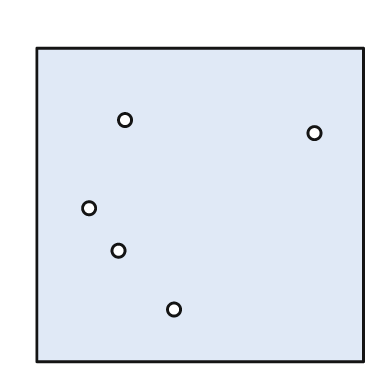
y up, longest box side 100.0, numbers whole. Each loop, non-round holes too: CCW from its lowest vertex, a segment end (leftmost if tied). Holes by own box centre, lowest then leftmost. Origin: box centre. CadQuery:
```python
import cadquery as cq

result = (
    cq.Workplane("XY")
    .moveTo(-50.0, -48.0)
    .lineTo(50.0, -48.0)
    .lineTo(50.0, 48.0)
    .lineTo(-50.0, 48.0)
    .close()
    .moveTo(-8.0, -32.0)
    .circle(2.0)
    .moveTo(-25.0, -14.0)
    .circle(2.0)
    .moveTo(-34.0, -1.0)
    .circle(2.0)
    .moveTo(35.0, 22.0)
    .circle(2.0)
    .moveTo(-23.0, 26.0)
    .circle(2.0)
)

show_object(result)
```